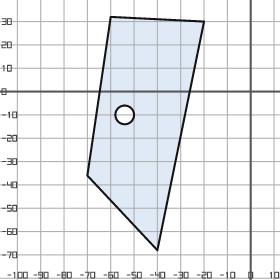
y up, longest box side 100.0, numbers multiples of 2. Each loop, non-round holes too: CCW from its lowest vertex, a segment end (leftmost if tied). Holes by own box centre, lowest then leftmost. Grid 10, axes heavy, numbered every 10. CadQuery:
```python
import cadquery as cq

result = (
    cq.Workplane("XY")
    .moveTo(-40.0, -68.0)
    .lineTo(-20.0, 30.0)
    .lineTo(-60.0, 32.0)
    .lineTo(-70.0, -36.0)
    .close()
    .moveTo(-54.0, -10.0)
    .circle(4.0)
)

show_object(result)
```